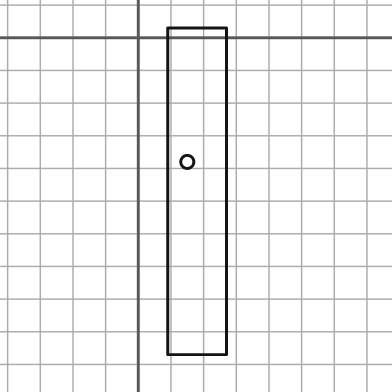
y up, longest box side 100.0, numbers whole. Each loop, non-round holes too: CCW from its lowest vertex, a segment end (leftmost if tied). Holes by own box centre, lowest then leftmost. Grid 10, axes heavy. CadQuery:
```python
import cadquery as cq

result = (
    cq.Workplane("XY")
    .moveTo(9.0, -97.0)
    .lineTo(27.0, -97.0)
    .lineTo(27.0, 3.0)
    .lineTo(9.0, 3.0)
    .close()
    .moveTo(15.0, -38.0)
    .circle(2.0)
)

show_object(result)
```